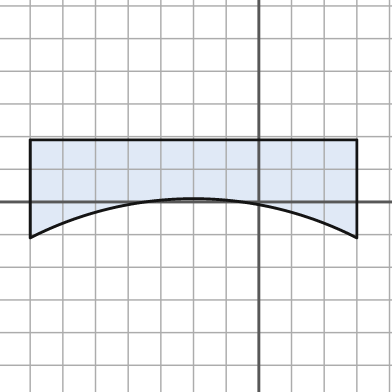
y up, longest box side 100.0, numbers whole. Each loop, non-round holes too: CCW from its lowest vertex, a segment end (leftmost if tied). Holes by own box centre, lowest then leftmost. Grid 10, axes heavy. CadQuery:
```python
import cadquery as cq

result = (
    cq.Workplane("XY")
    .moveTo(-70.0, -11.0)
    .threePointArc((-20.0, 1.0), (30.0, -11.0))
    .lineTo(30.0, 19.0)
    .lineTo(-70.0, 19.0)
    .close()
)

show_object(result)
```